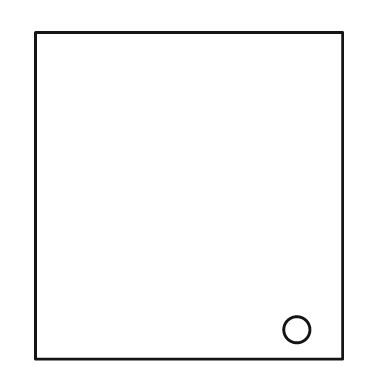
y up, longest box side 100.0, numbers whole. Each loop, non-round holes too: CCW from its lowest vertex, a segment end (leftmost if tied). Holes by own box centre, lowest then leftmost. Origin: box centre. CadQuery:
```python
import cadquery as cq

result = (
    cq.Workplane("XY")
    .moveTo(-47.0, -50.0)
    .lineTo(47.0, -50.0)
    .lineTo(47.0, 50.0)
    .lineTo(-47.0, 50.0)
    .close()
    .moveTo(33.0, -41.0)
    .circle(4.0)
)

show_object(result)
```